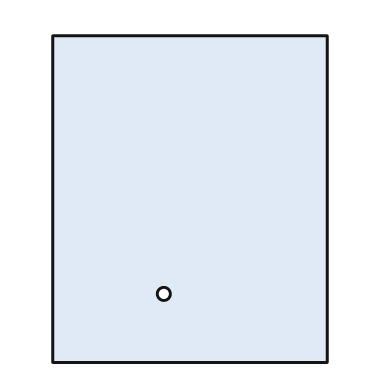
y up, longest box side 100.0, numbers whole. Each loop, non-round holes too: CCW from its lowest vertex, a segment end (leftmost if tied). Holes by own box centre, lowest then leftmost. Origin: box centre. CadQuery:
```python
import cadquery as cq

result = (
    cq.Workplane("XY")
    .moveTo(-42.0, -50.0)
    .lineTo(42.0, -50.0)
    .lineTo(42.0, 50.0)
    .lineTo(-42.0, 50.0)
    .close()
    .moveTo(-8.0, -29.0)
    .circle(2.0)
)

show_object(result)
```